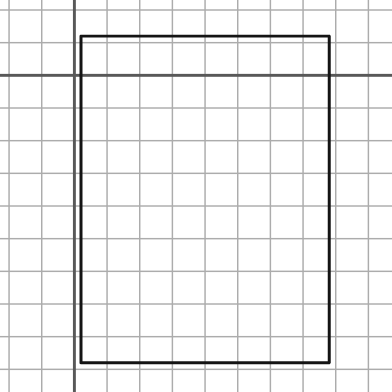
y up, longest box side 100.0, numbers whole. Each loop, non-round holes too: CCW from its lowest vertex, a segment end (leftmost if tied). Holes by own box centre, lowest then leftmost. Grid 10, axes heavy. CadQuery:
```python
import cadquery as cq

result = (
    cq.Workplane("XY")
    .moveTo(2.0, -88.0)
    .lineTo(78.0, -88.0)
    .lineTo(78.0, 12.0)
    .lineTo(2.0, 12.0)
    .close()
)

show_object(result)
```